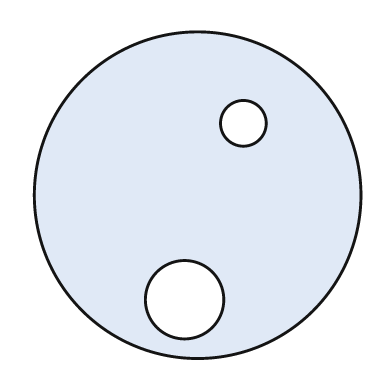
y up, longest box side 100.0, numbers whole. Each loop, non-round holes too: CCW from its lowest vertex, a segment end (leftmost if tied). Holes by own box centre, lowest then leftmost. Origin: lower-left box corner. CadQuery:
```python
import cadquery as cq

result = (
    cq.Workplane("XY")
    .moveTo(50.0, 50.0)
    .circle(50.0)
    .moveTo(46.0, 18.0)
    .circle(12.0)
    .moveTo(64.0, 72.0)
    .circle(7.0)
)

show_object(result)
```